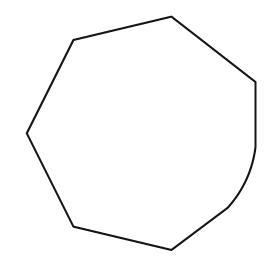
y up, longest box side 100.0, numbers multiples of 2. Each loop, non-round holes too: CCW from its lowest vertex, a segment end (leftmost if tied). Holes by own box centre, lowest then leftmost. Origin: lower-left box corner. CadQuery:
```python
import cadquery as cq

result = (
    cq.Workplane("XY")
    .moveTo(62.0, 0.0)
    .lineTo(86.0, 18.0)
    .threePointArc((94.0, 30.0), (98.0, 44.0))
    .lineTo(98.0, 72.0)
    .lineTo(62.0, 100.0)
    .lineTo(20.0, 90.0)
    .lineTo(0.0, 50.0)
    .lineTo(20.0, 10.0)
    .close()
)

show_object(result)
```